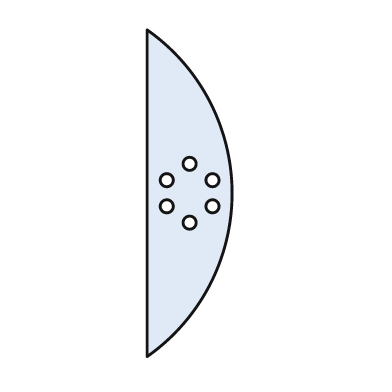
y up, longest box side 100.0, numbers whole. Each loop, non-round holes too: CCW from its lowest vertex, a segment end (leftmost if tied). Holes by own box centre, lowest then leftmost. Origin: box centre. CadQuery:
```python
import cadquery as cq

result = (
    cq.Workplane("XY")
    .moveTo(-13.0, -50.0)
    .threePointArc((13.0, 0.0), (-13.0, 50.0))
    .close()
    .moveTo(0.0, -9.0)
    .circle(2.0)
    .moveTo(-7.0, -4.0)
    .circle(2.0)
    .moveTo(7.0, -4.0)
    .circle(2.0)
    .moveTo(-7.0, 4.0)
    .circle(2.0)
    .moveTo(7.0, 4.0)
    .circle(2.0)
    .moveTo(0.0, 9.0)
    .circle(2.0)
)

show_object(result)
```